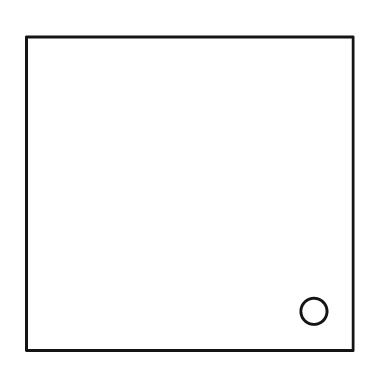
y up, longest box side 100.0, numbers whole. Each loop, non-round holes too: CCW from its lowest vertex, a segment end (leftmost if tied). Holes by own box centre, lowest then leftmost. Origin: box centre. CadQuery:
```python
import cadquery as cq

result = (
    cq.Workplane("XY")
    .moveTo(-50.0, -48.0)
    .lineTo(50.0, -48.0)
    .lineTo(50.0, 48.0)
    .lineTo(-50.0, 48.0)
    .close()
    .moveTo(38.0, -36.0)
    .circle(4.0)
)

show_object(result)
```